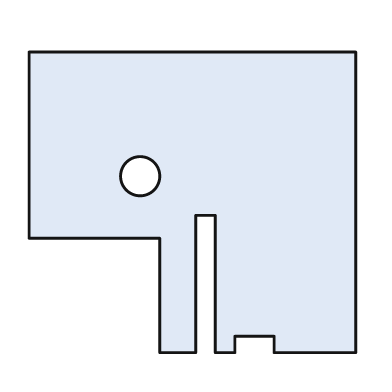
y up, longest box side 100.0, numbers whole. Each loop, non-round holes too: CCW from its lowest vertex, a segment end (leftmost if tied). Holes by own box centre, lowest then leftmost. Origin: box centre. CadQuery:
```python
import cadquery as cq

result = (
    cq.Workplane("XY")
    .moveTo(-10.0, -46.0)
    .lineTo(1.0, -46.0)
    .lineTo(1.0, -4.0)
    .lineTo(7.0, -4.0)
    .lineTo(7.0, -46.0)
    .lineTo(13.0, -46.0)
    .lineTo(13.0, -41.0)
    .lineTo(25.0, -41.0)
    .lineTo(25.0, -46.0)
    .lineTo(50.0, -46.0)
    .lineTo(50.0, 46.0)
    .lineTo(-50.0, 46.0)
    .lineTo(-50.0, -11.0)
    .lineTo(-10.0, -11.0)
    .close()
    .moveTo(-16.0, 8.0)
    .circle(6.0)
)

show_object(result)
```